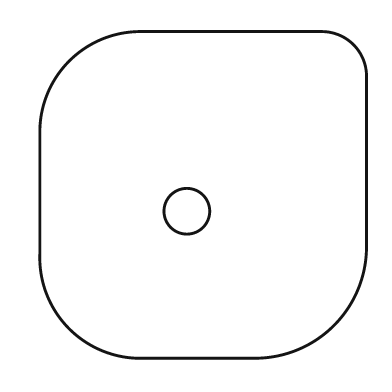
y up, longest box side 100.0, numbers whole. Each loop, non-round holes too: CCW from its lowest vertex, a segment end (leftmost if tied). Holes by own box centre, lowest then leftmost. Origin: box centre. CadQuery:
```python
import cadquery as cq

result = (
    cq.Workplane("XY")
    .moveTo(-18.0, -50.0)
    .lineTo(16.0, -50.0)
    .threePointArc((40.0, -40.0), (50.0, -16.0))
    .lineTo(50.0, 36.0)
    .threePointArc((46.0, 46.0), (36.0, 50.0))
    .lineTo(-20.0, 50.0)
    .threePointArc((-41.0, 41.0), (-50.0, 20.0))
    .lineTo(-50.0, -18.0)
    .threePointArc((-41.0, -41.0), (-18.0, -50.0))
    .close()
    .moveTo(-5.0, -5.0)
    .circle(7.0)
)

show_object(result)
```